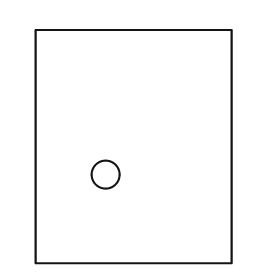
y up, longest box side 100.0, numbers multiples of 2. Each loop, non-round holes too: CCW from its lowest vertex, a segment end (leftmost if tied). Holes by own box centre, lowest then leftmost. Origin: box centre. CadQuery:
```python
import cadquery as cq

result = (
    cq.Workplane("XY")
    .moveTo(-42.0, -50.0)
    .lineTo(42.0, -50.0)
    .lineTo(42.0, 50.0)
    .lineTo(-42.0, 50.0)
    .close()
    .moveTo(-12.0, -12.0)
    .circle(6.0)
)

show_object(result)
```